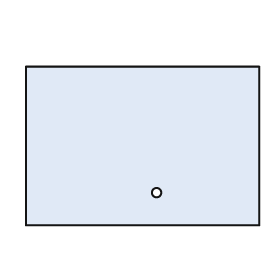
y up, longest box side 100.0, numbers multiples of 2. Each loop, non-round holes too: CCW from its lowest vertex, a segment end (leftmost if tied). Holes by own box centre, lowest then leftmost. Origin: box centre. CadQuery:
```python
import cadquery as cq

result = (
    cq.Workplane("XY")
    .moveTo(-50.0, -34.0)
    .lineTo(50.0, -34.0)
    .lineTo(50.0, 34.0)
    .lineTo(-50.0, 34.0)
    .close()
    .moveTo(6.0, -20.0)
    .circle(2.0)
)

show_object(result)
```